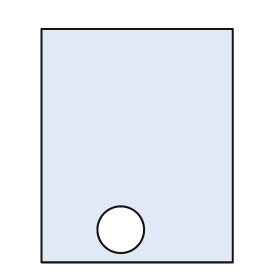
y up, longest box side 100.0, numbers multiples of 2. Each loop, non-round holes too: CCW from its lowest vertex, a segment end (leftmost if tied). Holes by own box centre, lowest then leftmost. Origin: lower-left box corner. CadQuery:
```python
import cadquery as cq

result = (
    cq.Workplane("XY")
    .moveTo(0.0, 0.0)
    .lineTo(82.0, 0.0)
    .lineTo(82.0, 100.0)
    .lineTo(0.0, 100.0)
    .close()
    .moveTo(34.0, 14.0)
    .circle(10.0)
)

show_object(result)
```